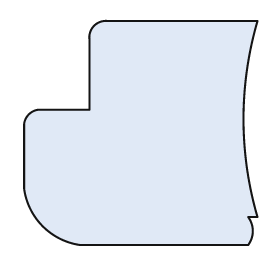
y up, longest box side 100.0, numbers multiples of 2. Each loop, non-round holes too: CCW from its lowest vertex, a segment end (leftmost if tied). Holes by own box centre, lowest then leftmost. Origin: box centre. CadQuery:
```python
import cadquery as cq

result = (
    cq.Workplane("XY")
    .moveTo(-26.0, -48.0)
    .lineTo(46.0, -48.0)
    .threePointArc((48.0, -42.0), (46.0, -36.0))
    .lineTo(50.0, -36.0)
    .threePointArc((44.0, 6.0), (50.0, 48.0))
    .lineTo(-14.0, 48.0)
    .threePointArc((-20.0, 46.0), (-22.0, 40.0))
    .lineTo(-22.0, 10.0)
    .lineTo(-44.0, 10.0)
    .threePointArc((-48.0, 8.0), (-50.0, 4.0))
    .lineTo(-50.0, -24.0)
    .threePointArc((-42.0, -40.0), (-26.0, -48.0))
    .close()
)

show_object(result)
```